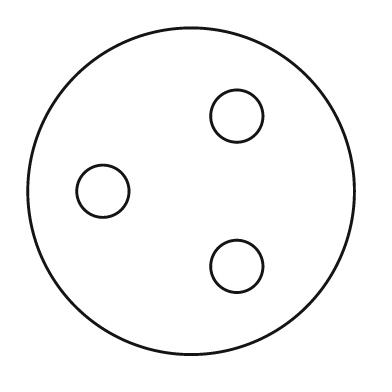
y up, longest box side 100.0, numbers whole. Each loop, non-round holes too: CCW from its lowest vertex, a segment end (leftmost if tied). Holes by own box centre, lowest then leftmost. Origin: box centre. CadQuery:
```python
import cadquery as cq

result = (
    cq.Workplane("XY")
    .moveTo(0.0, 0.0)
    .circle(50.0)
    .moveTo(14.0, -23.0)
    .circle(8.0)
    .moveTo(-27.0, 0.0)
    .circle(8.0)
    .moveTo(14.0, 23.0)
    .circle(8.0)
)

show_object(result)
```